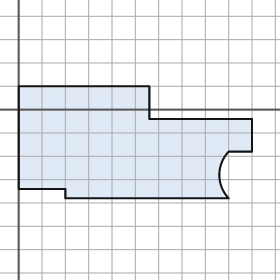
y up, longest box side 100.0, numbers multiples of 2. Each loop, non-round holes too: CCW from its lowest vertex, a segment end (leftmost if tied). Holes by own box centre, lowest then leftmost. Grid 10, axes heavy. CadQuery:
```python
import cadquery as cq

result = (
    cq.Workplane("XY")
    .moveTo(20.0, -38.0)
    .lineTo(90.0, -38.0)
    .threePointArc((86.0, -28.0), (90.0, -18.0))
    .lineTo(100.0, -18.0)
    .lineTo(100.0, -4.0)
    .lineTo(56.0, -4.0)
    .lineTo(56.0, 10.0)
    .lineTo(0.0, 10.0)
    .lineTo(0.0, -34.0)
    .lineTo(20.0, -34.0)
    .close()
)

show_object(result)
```